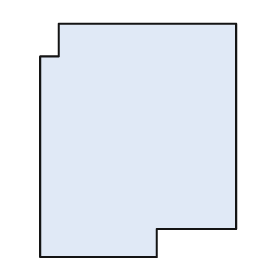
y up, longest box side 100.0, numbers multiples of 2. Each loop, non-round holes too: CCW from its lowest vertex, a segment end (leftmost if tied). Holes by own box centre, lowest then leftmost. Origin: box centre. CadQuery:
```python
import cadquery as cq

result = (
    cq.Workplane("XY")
    .moveTo(-42.0, -50.0)
    .lineTo(8.0, -50.0)
    .lineTo(8.0, -38.0)
    .lineTo(42.0, -38.0)
    .lineTo(42.0, 50.0)
    .lineTo(-34.0, 50.0)
    .lineTo(-34.0, 36.0)
    .lineTo(-42.0, 36.0)
    .close()
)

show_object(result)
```